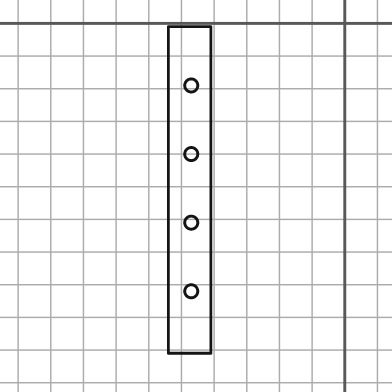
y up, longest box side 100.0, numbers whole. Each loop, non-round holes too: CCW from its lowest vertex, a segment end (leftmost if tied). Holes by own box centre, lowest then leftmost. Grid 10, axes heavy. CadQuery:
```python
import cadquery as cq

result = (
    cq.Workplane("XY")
    .moveTo(-54.0, -101.0)
    .lineTo(-41.0, -101.0)
    .lineTo(-41.0, -1.0)
    .lineTo(-54.0, -1.0)
    .close()
    .moveTo(-47.0, -82.0)
    .circle(2.0)
    .moveTo(-47.0, -61.0)
    .circle(2.0)
    .moveTo(-47.0, -40.0)
    .circle(2.0)
    .moveTo(-47.0, -19.0)
    .circle(2.0)
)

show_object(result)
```